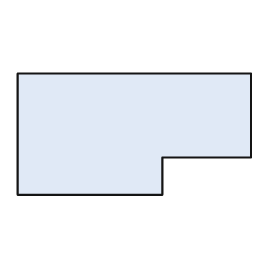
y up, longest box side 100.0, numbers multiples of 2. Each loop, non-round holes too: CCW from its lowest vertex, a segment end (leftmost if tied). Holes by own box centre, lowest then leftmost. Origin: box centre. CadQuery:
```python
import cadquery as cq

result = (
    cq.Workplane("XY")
    .moveTo(-50.0, -26.0)
    .lineTo(12.0, -26.0)
    .lineTo(12.0, -10.0)
    .lineTo(50.0, -10.0)
    .lineTo(50.0, 26.0)
    .lineTo(-50.0, 26.0)
    .close()
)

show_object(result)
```